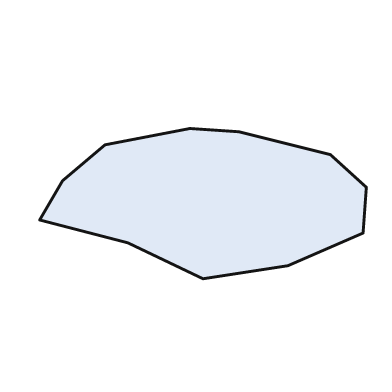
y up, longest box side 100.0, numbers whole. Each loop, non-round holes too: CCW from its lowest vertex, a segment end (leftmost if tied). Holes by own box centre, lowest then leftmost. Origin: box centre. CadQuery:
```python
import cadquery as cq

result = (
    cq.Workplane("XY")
    .moveTo(0.0, -23.0)
    .lineTo(26.0, -19.0)
    .lineTo(49.0, -9.0)
    .lineTo(50.0, 5.0)
    .lineTo(39.0, 15.0)
    .lineTo(11.0, 22.0)
    .lineTo(-4.0, 23.0)
    .lineTo(-30.0, 18.0)
    .lineTo(-43.0, 7.0)
    .lineTo(-50.0, -5.0)
    .lineTo(-23.0, -12.0)
    .close()
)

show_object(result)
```